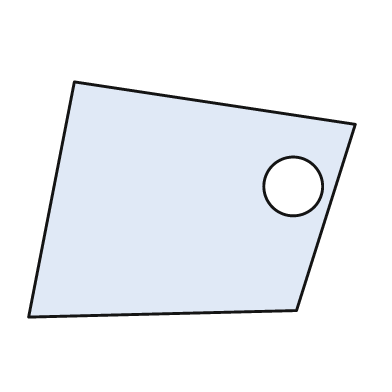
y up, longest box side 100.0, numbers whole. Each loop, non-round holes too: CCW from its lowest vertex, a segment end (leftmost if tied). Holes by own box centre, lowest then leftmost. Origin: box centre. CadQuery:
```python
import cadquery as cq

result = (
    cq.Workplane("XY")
    .moveTo(-50.0, -36.0)
    .lineTo(32.0, -34.0)
    .lineTo(50.0, 23.0)
    .lineTo(-36.0, 36.0)
    .close()
    .moveTo(31.0, 4.0)
    .circle(9.0)
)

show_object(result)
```